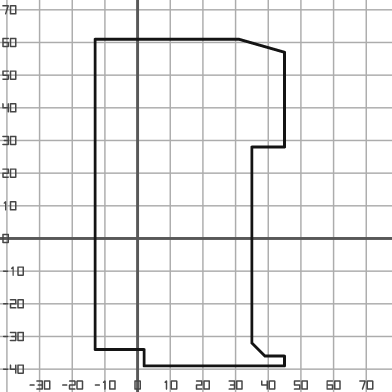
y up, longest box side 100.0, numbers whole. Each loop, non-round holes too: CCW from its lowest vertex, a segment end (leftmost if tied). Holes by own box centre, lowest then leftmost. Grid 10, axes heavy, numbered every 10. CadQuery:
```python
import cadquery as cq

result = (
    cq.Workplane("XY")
    .moveTo(2.0, -39.0)
    .lineTo(45.0, -39.0)
    .lineTo(45.0, -36.0)
    .lineTo(39.0, -36.0)
    .lineTo(35.0, -32.0)
    .lineTo(35.0, 28.0)
    .lineTo(45.0, 28.0)
    .lineTo(45.0, 57.0)
    .lineTo(31.0, 61.0)
    .lineTo(-13.0, 61.0)
    .lineTo(-13.0, -34.0)
    .lineTo(2.0, -34.0)
    .close()
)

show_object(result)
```